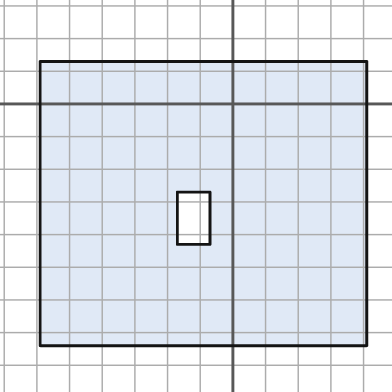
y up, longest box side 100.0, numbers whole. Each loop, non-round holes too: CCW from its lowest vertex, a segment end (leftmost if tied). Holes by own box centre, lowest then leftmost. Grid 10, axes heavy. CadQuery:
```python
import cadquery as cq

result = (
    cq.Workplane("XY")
    .moveTo(-59.0, -74.0)
    .lineTo(41.0, -74.0)
    .lineTo(41.0, 13.0)
    .lineTo(-59.0, 13.0)
    .close()
    .moveTo(-17.0, -43.0)
    .lineTo(-7.0, -43.0)
    .lineTo(-7.0, -27.0)
    .lineTo(-17.0, -27.0)
    .close()
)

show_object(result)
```